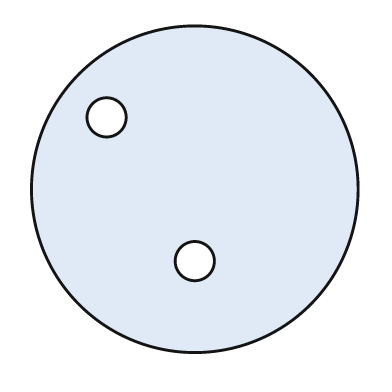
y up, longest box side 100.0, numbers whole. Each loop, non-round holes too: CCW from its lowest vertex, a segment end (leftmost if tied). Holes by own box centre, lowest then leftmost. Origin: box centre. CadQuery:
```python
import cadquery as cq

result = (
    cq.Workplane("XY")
    .moveTo(0.0, 0.0)
    .circle(50.0)
    .moveTo(0.0, -22.0)
    .circle(6.0)
    .moveTo(-27.0, 22.0)
    .circle(6.0)
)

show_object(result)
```